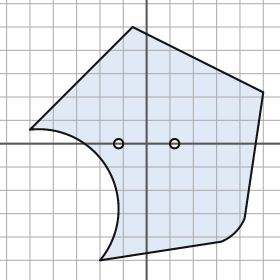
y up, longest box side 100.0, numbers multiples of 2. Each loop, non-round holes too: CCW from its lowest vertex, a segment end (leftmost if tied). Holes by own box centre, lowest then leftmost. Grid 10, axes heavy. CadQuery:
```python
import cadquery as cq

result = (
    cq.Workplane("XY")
    .moveTo(-20.0, -50.0)
    .lineTo(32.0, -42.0)
    .threePointArc((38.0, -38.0), (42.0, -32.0))
    .lineTo(50.0, 22.0)
    .lineTo(-6.0, 50.0)
    .lineTo(-50.0, 6.0)
    .threePointArc((-16.0, -12.0), (-20.0, -50.0))
    .close()
    .moveTo(-12.0, 0.0)
    .circle(2.0)
    .moveTo(12.0, 0.0)
    .circle(2.0)
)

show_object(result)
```